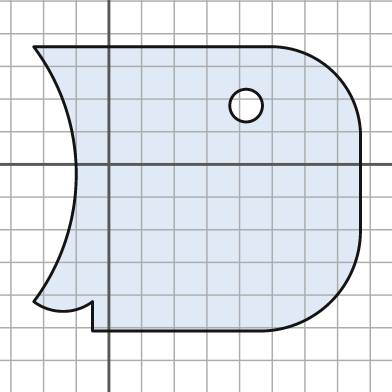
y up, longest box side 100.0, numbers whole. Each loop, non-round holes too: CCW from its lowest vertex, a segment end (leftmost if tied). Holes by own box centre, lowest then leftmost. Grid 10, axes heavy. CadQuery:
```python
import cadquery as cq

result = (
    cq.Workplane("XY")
    .moveTo(-5.0, -51.0)
    .lineTo(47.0, -51.0)
    .threePointArc((68.0, -42.0), (77.0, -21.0))
    .lineTo(77.0, 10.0)
    .threePointArc((69.0, 28.0), (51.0, 36.0))
    .lineTo(-23.0, 36.0)
    .threePointArc((-10.0, -3.0), (-23.0, -42.0))
    .threePointArc((-14.0, -45.0), (-5.0, -42.0))
    .close()
    .moveTo(42.0, 18.0)
    .circle(5.0)
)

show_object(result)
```